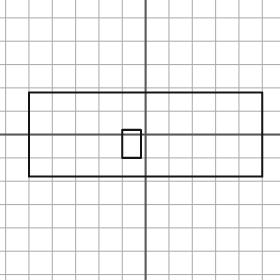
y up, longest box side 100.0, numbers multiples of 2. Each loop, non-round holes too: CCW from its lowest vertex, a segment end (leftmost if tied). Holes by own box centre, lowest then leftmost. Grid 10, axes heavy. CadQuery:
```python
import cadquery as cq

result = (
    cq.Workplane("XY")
    .moveTo(-50.0, -18.0)
    .lineTo(50.0, -18.0)
    .lineTo(50.0, 18.0)
    .lineTo(-50.0, 18.0)
    .close()
    .moveTo(-10.0, -10.0)
    .lineTo(-2.0, -10.0)
    .lineTo(-2.0, 2.0)
    .lineTo(-10.0, 2.0)
    .close()
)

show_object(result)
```